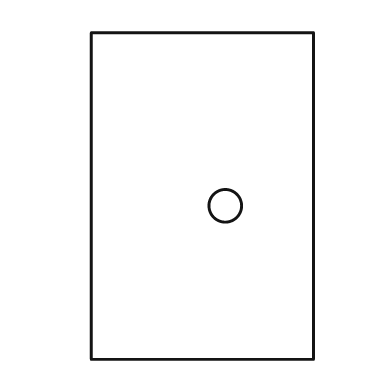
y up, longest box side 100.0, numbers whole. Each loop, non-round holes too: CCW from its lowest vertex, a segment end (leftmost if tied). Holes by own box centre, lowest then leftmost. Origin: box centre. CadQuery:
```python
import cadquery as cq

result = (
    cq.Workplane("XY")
    .moveTo(-34.0, -50.0)
    .lineTo(34.0, -50.0)
    .lineTo(34.0, 50.0)
    .lineTo(-34.0, 50.0)
    .close()
    .moveTo(7.0, -3.0)
    .circle(5.0)
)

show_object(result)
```